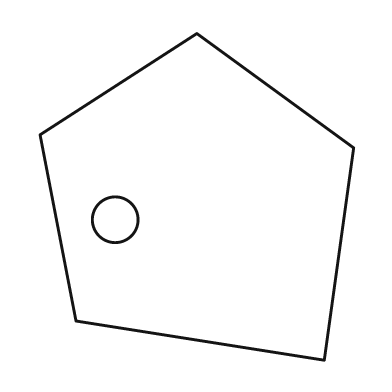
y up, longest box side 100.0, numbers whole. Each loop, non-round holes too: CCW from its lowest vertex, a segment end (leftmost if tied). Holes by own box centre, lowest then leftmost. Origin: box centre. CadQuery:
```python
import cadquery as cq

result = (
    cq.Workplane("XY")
    .moveTo(39.0, -50.0)
    .lineTo(48.0, 15.0)
    .lineTo(0.0, 50.0)
    .lineTo(-48.0, 19.0)
    .lineTo(-37.0, -38.0)
    .close()
    .moveTo(-25.0, -7.0)
    .circle(7.0)
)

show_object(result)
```